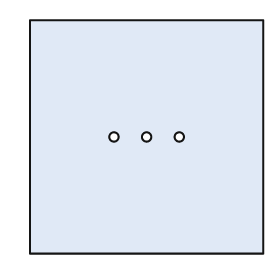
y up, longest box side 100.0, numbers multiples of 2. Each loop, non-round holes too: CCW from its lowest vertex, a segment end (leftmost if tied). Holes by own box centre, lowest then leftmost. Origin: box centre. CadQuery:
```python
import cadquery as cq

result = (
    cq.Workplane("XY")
    .moveTo(-50.0, -50.0)
    .lineTo(50.0, -50.0)
    .lineTo(50.0, 50.0)
    .lineTo(-50.0, 50.0)
    .close()
    .moveTo(-14.0, 0.0)
    .circle(2.0)
    .moveTo(0.0, 0.0)
    .circle(2.0)
    .moveTo(14.0, 0.0)
    .circle(2.0)
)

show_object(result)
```